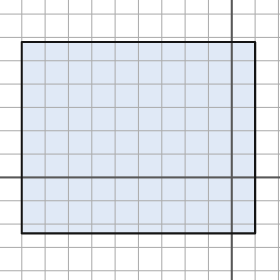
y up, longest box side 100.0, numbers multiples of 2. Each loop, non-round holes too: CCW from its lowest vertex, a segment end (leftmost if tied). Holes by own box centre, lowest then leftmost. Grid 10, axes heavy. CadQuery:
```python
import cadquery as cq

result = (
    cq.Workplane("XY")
    .moveTo(-90.0, -24.0)
    .lineTo(10.0, -24.0)
    .lineTo(10.0, 58.0)
    .lineTo(-90.0, 58.0)
    .close()
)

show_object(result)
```